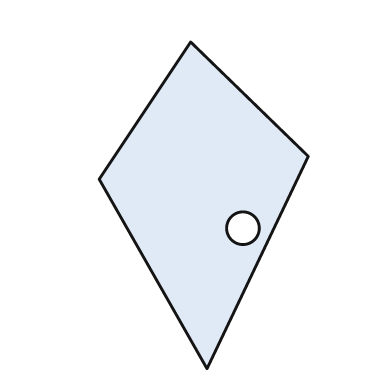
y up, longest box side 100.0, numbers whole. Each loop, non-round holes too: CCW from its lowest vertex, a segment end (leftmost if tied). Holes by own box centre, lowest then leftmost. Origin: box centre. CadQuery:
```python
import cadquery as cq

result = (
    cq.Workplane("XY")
    .moveTo(1.0, -50.0)
    .lineTo(32.0, 15.0)
    .lineTo(-4.0, 50.0)
    .lineTo(-32.0, 8.0)
    .close()
    .moveTo(12.0, -7.0)
    .circle(5.0)
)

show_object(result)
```